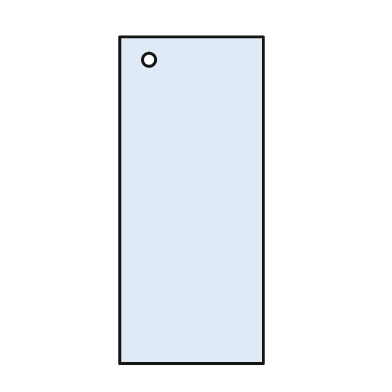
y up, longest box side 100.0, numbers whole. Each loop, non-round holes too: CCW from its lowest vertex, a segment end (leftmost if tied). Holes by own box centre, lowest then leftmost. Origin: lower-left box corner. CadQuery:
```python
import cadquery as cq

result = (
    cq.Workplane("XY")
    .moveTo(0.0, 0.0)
    .lineTo(44.0, 0.0)
    .lineTo(44.0, 100.0)
    .lineTo(0.0, 100.0)
    .close()
    .moveTo(9.0, 93.0)
    .circle(2.0)
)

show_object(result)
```